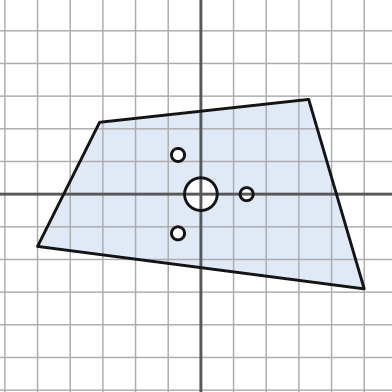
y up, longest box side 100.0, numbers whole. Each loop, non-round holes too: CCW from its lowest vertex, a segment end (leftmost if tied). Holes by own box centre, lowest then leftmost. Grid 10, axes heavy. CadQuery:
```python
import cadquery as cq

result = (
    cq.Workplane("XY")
    .moveTo(50.0, -29.0)
    .lineTo(33.0, 29.0)
    .lineTo(-31.0, 22.0)
    .lineTo(-50.0, -16.0)
    .close()
    .moveTo(-7.0, -12.0)
    .circle(2.0)
    .moveTo(0.0, 0.0)
    .circle(5.0)
    .moveTo(14.0, 0.0)
    .circle(2.0)
    .moveTo(-7.0, 12.0)
    .circle(2.0)
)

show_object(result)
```